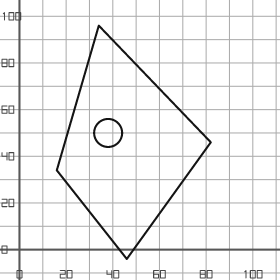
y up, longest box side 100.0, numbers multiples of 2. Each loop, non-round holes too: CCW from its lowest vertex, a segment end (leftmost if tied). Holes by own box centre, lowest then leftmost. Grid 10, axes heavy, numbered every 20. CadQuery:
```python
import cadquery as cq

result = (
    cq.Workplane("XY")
    .moveTo(46.0, -4.0)
    .lineTo(82.0, 46.0)
    .lineTo(34.0, 96.0)
    .lineTo(16.0, 34.0)
    .close()
    .moveTo(38.0, 50.0)
    .circle(6.0)
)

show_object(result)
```